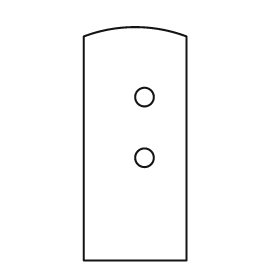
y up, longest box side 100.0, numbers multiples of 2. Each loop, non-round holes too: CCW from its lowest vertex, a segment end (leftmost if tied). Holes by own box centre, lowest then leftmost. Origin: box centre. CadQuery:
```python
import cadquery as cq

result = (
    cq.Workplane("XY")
    .moveTo(-22.0, -50.0)
    .lineTo(22.0, -50.0)
    .lineTo(22.0, 46.0)
    .threePointArc((0.0, 50.0), (-22.0, 46.0))
    .close()
    .moveTo(4.0, -6.0)
    .circle(4.0)
    .moveTo(4.0, 20.0)
    .circle(4.0)
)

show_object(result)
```